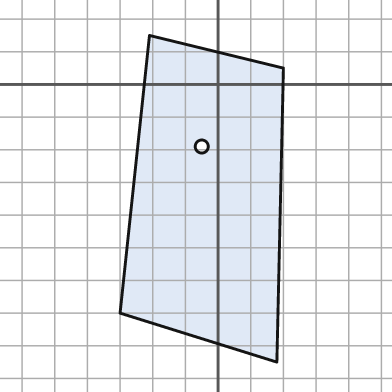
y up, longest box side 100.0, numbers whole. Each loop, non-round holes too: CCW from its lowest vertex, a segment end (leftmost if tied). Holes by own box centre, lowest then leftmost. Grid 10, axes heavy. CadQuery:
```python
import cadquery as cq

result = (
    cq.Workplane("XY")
    .moveTo(18.0, -85.0)
    .lineTo(20.0, 5.0)
    .lineTo(-21.0, 15.0)
    .lineTo(-30.0, -70.0)
    .close()
    .moveTo(-5.0, -19.0)
    .circle(2.0)
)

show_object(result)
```